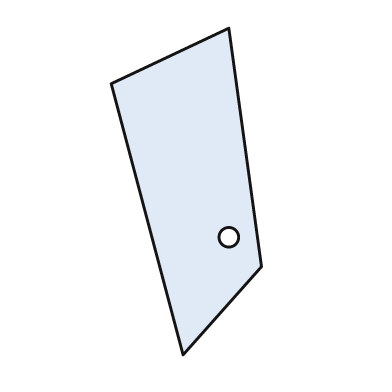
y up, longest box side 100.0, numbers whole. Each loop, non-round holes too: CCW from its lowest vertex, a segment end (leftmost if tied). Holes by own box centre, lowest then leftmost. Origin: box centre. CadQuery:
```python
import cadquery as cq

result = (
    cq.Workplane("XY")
    .moveTo(-1.0, -50.0)
    .lineTo(23.0, -23.0)
    .lineTo(13.0, 50.0)
    .lineTo(-23.0, 33.0)
    .close()
    .moveTo(13.0, -14.0)
    .circle(3.0)
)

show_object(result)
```